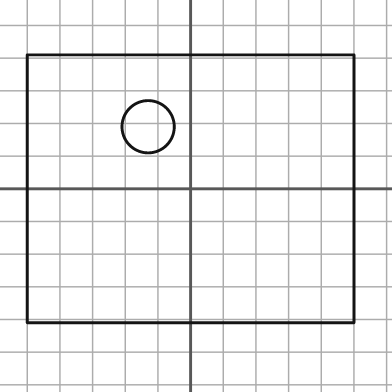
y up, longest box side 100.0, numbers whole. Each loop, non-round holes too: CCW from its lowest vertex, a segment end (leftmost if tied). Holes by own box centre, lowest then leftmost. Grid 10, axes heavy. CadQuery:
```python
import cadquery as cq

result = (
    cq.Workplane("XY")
    .moveTo(-50.0, -41.0)
    .lineTo(50.0, -41.0)
    .lineTo(50.0, 41.0)
    .lineTo(-50.0, 41.0)
    .close()
    .moveTo(-13.0, 19.0)
    .circle(8.0)
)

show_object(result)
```